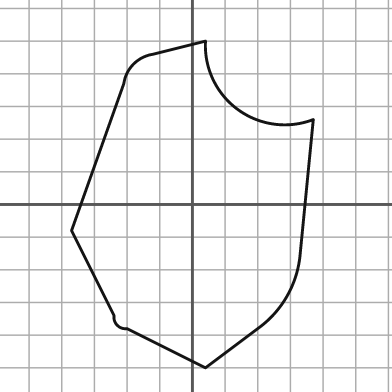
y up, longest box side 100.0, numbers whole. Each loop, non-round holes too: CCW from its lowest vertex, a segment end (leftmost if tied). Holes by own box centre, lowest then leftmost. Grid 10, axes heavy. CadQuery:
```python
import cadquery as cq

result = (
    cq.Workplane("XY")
    .moveTo(4.0, -50.0)
    .lineTo(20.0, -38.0)
    .threePointArc((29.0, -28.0), (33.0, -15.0))
    .lineTo(37.0, 26.0)
    .threePointArc((14.0, 29.0), (4.0, 50.0))
    .lineTo(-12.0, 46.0)
    .threePointArc((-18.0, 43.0), (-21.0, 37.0))
    .lineTo(-37.0, -8.0)
    .lineTo(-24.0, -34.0)
    .threePointArc((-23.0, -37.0), (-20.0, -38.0))
    .close()
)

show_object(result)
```